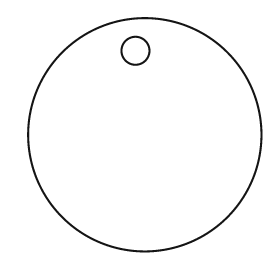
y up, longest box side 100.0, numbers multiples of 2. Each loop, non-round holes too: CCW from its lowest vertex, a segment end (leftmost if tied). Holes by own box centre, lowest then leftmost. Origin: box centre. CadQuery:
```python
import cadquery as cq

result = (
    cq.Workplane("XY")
    .moveTo(0.0, 0.0)
    .circle(50.0)
    .moveTo(-4.0, 36.0)
    .circle(6.0)
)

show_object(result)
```